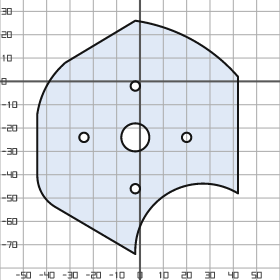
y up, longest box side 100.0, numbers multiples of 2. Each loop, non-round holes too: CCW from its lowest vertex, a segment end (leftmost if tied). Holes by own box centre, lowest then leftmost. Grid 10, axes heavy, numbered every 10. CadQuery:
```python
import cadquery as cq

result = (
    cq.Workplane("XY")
    .moveTo(-2.0, -74.0)
    .threePointArc((12.0, -48.0), (42.0, -48.0))
    .lineTo(42.0, 2.0)
    .threePointArc((22.0, 18.0), (-2.0, 26.0))
    .lineTo(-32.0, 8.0)
    .threePointArc((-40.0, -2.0), (-44.0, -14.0))
    .lineTo(-44.0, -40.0)
    .threePointArc((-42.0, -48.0), (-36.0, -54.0))
    .close()
    .moveTo(-2.0, -46.0)
    .circle(2.0)
    .moveTo(-24.0, -24.0)
    .circle(2.0)
    .moveTo(-2.0, -24.0)
    .circle(6.0)
    .moveTo(20.0, -24.0)
    .circle(2.0)
    .moveTo(-2.0, -2.0)
    .circle(2.0)
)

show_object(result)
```